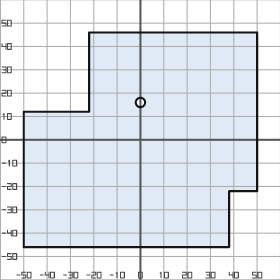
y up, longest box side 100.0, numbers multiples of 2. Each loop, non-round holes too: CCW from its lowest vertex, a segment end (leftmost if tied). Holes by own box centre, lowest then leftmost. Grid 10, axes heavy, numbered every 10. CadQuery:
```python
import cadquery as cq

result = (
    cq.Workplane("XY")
    .moveTo(-50.0, -46.0)
    .lineTo(38.0, -46.0)
    .lineTo(38.0, -22.0)
    .lineTo(50.0, -22.0)
    .lineTo(50.0, 46.0)
    .lineTo(-22.0, 46.0)
    .lineTo(-22.0, 12.0)
    .lineTo(-50.0, 12.0)
    .close()
    .moveTo(0.0, 16.0)
    .circle(2.0)
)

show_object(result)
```